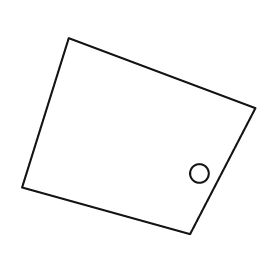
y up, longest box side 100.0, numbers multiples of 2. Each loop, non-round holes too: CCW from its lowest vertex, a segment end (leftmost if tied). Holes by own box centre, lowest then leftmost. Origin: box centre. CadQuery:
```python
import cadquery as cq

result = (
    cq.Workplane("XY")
    .moveTo(22.0, -42.0)
    .lineTo(50.0, 12.0)
    .lineTo(-30.0, 42.0)
    .lineTo(-50.0, -22.0)
    .close()
    .moveTo(26.0, -16.0)
    .circle(4.0)
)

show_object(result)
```